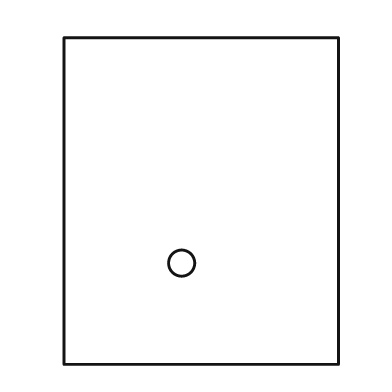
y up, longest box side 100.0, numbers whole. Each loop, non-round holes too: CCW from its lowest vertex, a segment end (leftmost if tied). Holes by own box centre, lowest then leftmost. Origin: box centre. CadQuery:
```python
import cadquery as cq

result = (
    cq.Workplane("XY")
    .moveTo(-42.0, -50.0)
    .lineTo(42.0, -50.0)
    .lineTo(42.0, 50.0)
    .lineTo(-42.0, 50.0)
    .close()
    .moveTo(-6.0, -19.0)
    .circle(4.0)
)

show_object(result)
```